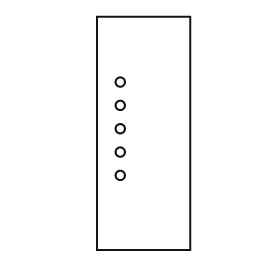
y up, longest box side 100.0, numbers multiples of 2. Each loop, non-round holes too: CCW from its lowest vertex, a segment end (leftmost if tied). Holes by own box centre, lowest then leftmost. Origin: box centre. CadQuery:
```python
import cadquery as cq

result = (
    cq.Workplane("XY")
    .moveTo(-20.0, -50.0)
    .lineTo(20.0, -50.0)
    .lineTo(20.0, 50.0)
    .lineTo(-20.0, 50.0)
    .close()
    .moveTo(-10.0, -18.0)
    .circle(2.0)
    .moveTo(-10.0, -8.0)
    .circle(2.0)
    .moveTo(-10.0, 2.0)
    .circle(2.0)
    .moveTo(-10.0, 12.0)
    .circle(2.0)
    .moveTo(-10.0, 22.0)
    .circle(2.0)
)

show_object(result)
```